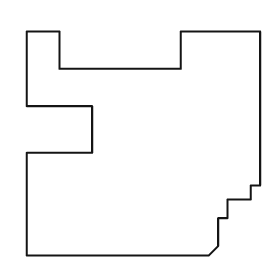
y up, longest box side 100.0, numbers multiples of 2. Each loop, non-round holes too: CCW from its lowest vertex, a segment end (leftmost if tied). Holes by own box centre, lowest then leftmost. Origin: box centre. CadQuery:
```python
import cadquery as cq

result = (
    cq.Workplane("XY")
    .moveTo(-50.0, -48.0)
    .lineTo(28.0, -48.0)
    .lineTo(32.0, -44.0)
    .lineTo(32.0, -32.0)
    .lineTo(36.0, -32.0)
    .lineTo(36.0, -24.0)
    .lineTo(46.0, -24.0)
    .lineTo(46.0, -18.0)
    .lineTo(50.0, -18.0)
    .lineTo(50.0, 48.0)
    .lineTo(16.0, 48.0)
    .lineTo(16.0, 32.0)
    .lineTo(-36.0, 32.0)
    .lineTo(-36.0, 48.0)
    .lineTo(-50.0, 48.0)
    .lineTo(-50.0, 16.0)
    .lineTo(-22.0, 16.0)
    .lineTo(-22.0, -4.0)
    .lineTo(-50.0, -4.0)
    .close()
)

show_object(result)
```